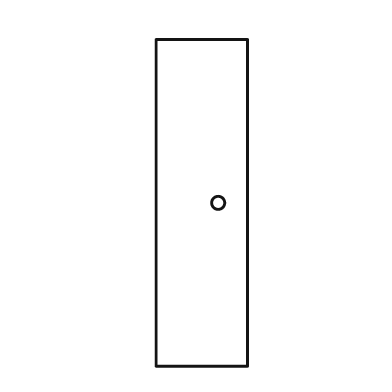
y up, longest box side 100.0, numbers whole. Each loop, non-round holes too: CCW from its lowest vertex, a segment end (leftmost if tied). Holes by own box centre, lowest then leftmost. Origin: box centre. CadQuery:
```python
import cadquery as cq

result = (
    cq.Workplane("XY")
    .moveTo(-14.0, -50.0)
    .lineTo(14.0, -50.0)
    .lineTo(14.0, 50.0)
    .lineTo(-14.0, 50.0)
    .close()
    .moveTo(5.0, 0.0)
    .circle(2.0)
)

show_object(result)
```